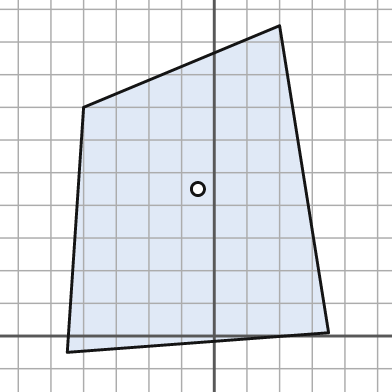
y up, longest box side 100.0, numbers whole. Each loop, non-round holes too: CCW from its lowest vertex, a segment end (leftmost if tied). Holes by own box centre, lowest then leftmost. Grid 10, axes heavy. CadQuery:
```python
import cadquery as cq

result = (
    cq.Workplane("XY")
    .moveTo(-45.0, -5.0)
    .lineTo(35.0, 1.0)
    .lineTo(20.0, 95.0)
    .lineTo(-40.0, 70.0)
    .close()
    .moveTo(-5.0, 45.0)
    .circle(2.0)
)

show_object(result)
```